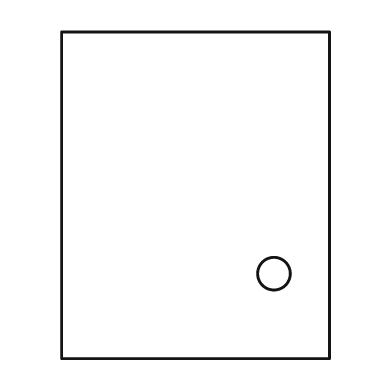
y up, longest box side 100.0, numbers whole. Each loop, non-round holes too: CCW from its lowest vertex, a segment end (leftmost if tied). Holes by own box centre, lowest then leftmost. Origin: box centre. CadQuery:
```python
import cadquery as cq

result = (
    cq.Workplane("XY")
    .moveTo(-41.0, -50.0)
    .lineTo(41.0, -50.0)
    .lineTo(41.0, 50.0)
    .lineTo(-41.0, 50.0)
    .close()
    .moveTo(24.0, -24.0)
    .circle(5.0)
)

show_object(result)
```